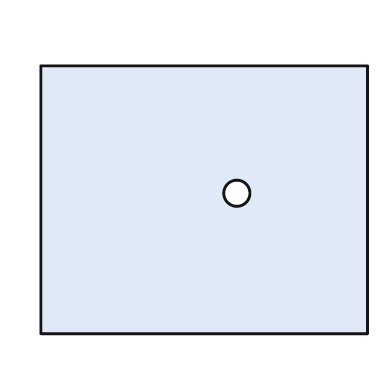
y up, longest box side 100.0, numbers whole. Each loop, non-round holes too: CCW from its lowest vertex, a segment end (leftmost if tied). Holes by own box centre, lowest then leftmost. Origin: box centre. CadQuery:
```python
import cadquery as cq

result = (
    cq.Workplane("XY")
    .moveTo(-50.0, -41.0)
    .lineTo(50.0, -41.0)
    .lineTo(50.0, 41.0)
    .lineTo(-50.0, 41.0)
    .close()
    .moveTo(10.0, 2.0)
    .circle(4.0)
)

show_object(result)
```